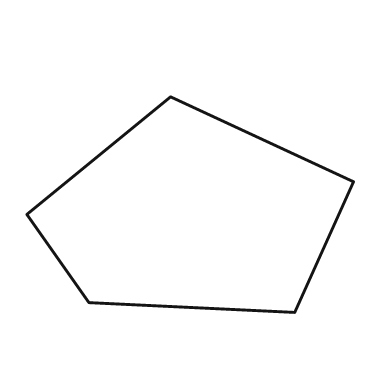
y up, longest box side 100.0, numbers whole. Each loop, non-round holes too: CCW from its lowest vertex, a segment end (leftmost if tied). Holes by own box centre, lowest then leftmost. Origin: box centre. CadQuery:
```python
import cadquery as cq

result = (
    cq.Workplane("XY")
    .moveTo(32.0, -33.0)
    .lineTo(50.0, 7.0)
    .lineTo(-6.0, 33.0)
    .lineTo(-50.0, -3.0)
    .lineTo(-31.0, -30.0)
    .close()
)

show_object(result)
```